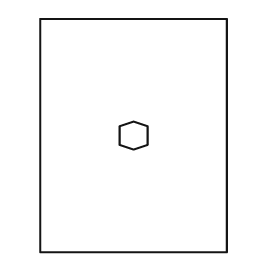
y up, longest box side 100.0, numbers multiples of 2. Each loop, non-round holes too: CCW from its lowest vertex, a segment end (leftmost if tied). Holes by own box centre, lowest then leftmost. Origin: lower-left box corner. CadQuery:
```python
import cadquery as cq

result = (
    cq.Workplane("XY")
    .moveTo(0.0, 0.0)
    .lineTo(80.0, 0.0)
    .lineTo(80.0, 100.0)
    .lineTo(0.0, 100.0)
    .close()
    .moveTo(40.0, 44.0)
    .lineTo(46.0, 46.0)
    .lineTo(46.0, 54.0)
    .lineTo(40.0, 56.0)
    .lineTo(34.0, 54.0)
    .lineTo(34.0, 46.0)
    .close()
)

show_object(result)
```